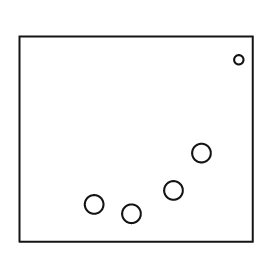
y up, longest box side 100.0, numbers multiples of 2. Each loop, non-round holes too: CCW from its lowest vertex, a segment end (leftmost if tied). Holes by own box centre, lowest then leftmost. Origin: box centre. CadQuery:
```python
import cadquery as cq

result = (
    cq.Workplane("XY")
    .moveTo(-50.0, -44.0)
    .lineTo(50.0, -44.0)
    .lineTo(50.0, 44.0)
    .lineTo(-50.0, 44.0)
    .close()
    .moveTo(-2.0, -32.0)
    .circle(4.0)
    .moveTo(-18.0, -28.0)
    .circle(4.0)
    .moveTo(16.0, -22.0)
    .circle(4.0)
    .moveTo(28.0, -6.0)
    .circle(4.0)
    .moveTo(44.0, 34.0)
    .circle(2.0)
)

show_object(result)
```